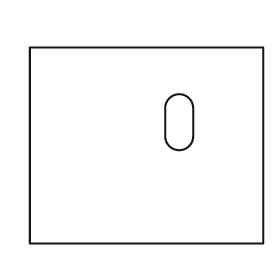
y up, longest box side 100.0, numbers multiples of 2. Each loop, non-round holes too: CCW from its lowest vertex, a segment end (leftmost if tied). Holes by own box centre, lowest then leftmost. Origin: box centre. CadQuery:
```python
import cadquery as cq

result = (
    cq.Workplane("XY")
    .moveTo(-50.0, -42.0)
    .lineTo(50.0, -42.0)
    .lineTo(50.0, 42.0)
    .lineTo(-50.0, 42.0)
    .close()
    .moveTo(8.0, 4.0)
    .threePointArc((14.0, -2.0), (20.0, 4.0))
    .lineTo(20.0, 16.0)
    .threePointArc((14.0, 22.0), (8.0, 16.0))
    .close()
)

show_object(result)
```